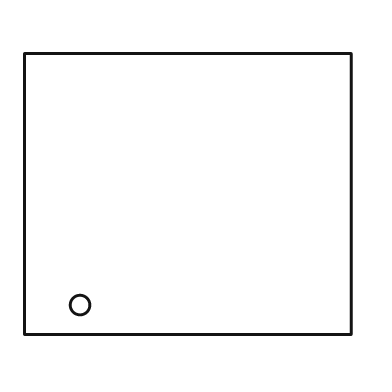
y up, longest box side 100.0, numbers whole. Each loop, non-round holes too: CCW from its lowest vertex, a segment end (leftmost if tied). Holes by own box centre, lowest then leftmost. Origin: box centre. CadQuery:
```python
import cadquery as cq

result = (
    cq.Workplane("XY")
    .moveTo(-50.0, -43.0)
    .lineTo(50.0, -43.0)
    .lineTo(50.0, 43.0)
    .lineTo(-50.0, 43.0)
    .close()
    .moveTo(-33.0, -34.0)
    .circle(3.0)
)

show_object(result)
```